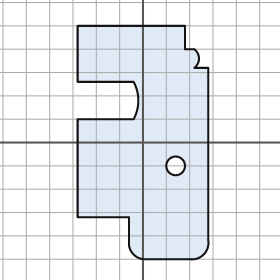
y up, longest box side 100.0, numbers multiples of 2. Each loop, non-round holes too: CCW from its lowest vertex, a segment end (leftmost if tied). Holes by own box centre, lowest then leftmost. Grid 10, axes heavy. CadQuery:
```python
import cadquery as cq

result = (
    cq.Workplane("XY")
    .moveTo(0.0, -50.0)
    .lineTo(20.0, -50.0)
    .threePointArc((26.0, -48.0), (28.0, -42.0))
    .lineTo(28.0, 32.0)
    .lineTo(22.0, 32.0)
    .threePointArc((24.0, 36.0), (22.0, 40.0))
    .lineTo(18.0, 40.0)
    .lineTo(18.0, 50.0)
    .lineTo(-28.0, 50.0)
    .lineTo(-28.0, 26.0)
    .lineTo(-4.0, 26.0)
    .threePointArc((-2.0, 18.0), (-4.0, 10.0))
    .lineTo(-28.0, 10.0)
    .lineTo(-28.0, -32.0)
    .lineTo(-6.0, -32.0)
    .lineTo(-6.0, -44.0)
    .threePointArc((-4.0, -48.0), (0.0, -50.0))
    .close()
    .moveTo(14.0, -10.0)
    .circle(4.0)
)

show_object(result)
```